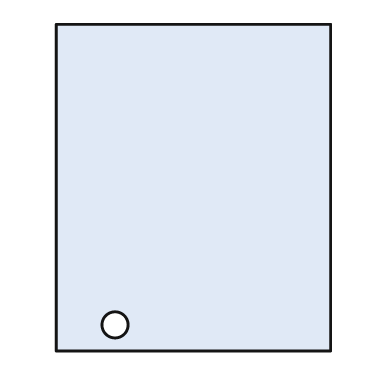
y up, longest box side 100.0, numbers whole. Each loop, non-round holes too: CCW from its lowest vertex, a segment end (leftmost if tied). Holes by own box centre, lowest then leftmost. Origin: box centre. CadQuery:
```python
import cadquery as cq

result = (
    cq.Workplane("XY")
    .moveTo(-42.0, -50.0)
    .lineTo(42.0, -50.0)
    .lineTo(42.0, 50.0)
    .lineTo(-42.0, 50.0)
    .close()
    .moveTo(-24.0, -42.0)
    .circle(4.0)
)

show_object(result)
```